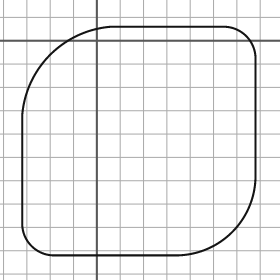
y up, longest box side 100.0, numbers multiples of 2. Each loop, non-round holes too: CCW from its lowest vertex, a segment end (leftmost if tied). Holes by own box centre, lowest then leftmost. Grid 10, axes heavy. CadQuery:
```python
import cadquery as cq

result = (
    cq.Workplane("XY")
    .moveTo(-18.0, -92.0)
    .lineTo(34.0, -92.0)
    .threePointArc((58.0, -82.0), (68.0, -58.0))
    .lineTo(68.0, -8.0)
    .threePointArc((64.0, 2.0), (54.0, 6.0))
    .lineTo(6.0, 6.0)
    .threePointArc((-20.0, -6.0), (-32.0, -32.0))
    .lineTo(-32.0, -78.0)
    .threePointArc((-28.0, -88.0), (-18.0, -92.0))
    .close()
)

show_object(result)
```